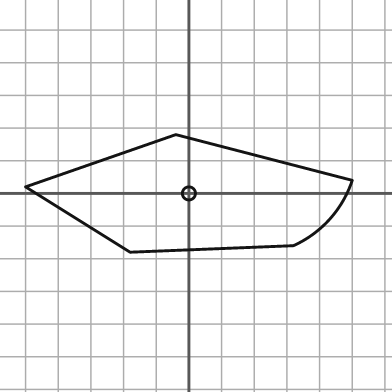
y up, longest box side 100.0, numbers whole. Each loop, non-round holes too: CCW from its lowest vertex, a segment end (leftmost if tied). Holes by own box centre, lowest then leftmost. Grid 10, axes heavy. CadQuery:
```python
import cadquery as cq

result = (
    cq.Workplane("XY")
    .moveTo(-18.0, -18.0)
    .lineTo(32.0, -16.0)
    .threePointArc((43.0, -8.0), (50.0, 4.0))
    .lineTo(-4.0, 18.0)
    .lineTo(-50.0, 2.0)
    .close()
    .moveTo(0.0, 0.0)
    .circle(2.0)
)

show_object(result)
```